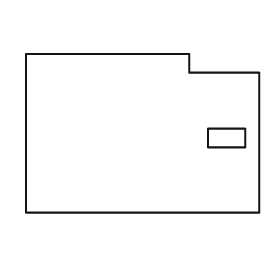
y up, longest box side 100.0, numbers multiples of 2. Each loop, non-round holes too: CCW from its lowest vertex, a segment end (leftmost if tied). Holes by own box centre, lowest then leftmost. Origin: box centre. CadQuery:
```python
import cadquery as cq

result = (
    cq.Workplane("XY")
    .moveTo(-50.0, -34.0)
    .lineTo(50.0, -34.0)
    .lineTo(50.0, 26.0)
    .lineTo(20.0, 26.0)
    .lineTo(20.0, 34.0)
    .lineTo(-50.0, 34.0)
    .close()
    .moveTo(28.0, -6.0)
    .lineTo(44.0, -6.0)
    .lineTo(44.0, 2.0)
    .lineTo(28.0, 2.0)
    .close()
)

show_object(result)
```